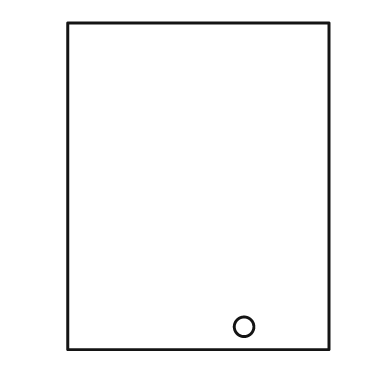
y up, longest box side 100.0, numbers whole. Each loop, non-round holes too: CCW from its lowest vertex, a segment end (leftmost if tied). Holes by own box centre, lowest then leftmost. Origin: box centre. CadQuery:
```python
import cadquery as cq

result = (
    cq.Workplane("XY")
    .moveTo(-40.0, -50.0)
    .lineTo(40.0, -50.0)
    .lineTo(40.0, 50.0)
    .lineTo(-40.0, 50.0)
    .close()
    .moveTo(14.0, -43.0)
    .circle(3.0)
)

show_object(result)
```